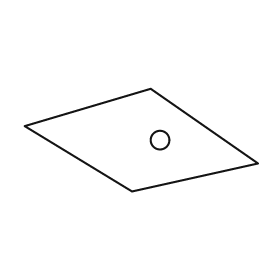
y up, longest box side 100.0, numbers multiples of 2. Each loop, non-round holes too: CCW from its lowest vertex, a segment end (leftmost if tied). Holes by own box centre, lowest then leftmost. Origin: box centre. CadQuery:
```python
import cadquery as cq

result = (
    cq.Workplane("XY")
    .moveTo(-4.0, -22.0)
    .lineTo(50.0, -10.0)
    .lineTo(4.0, 22.0)
    .lineTo(-50.0, 6.0)
    .close()
    .moveTo(8.0, 0.0)
    .circle(4.0)
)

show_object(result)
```